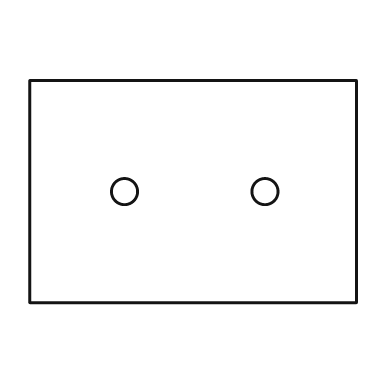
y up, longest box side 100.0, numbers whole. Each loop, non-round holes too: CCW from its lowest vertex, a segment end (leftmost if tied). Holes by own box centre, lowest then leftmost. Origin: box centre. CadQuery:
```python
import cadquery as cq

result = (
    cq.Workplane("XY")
    .moveTo(-50.0, -34.0)
    .lineTo(50.0, -34.0)
    .lineTo(50.0, 34.0)
    .lineTo(-50.0, 34.0)
    .close()
    .moveTo(-21.0, 0.0)
    .circle(4.0)
    .moveTo(22.0, 0.0)
    .circle(4.0)
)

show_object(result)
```